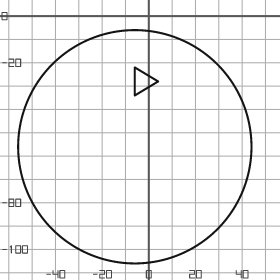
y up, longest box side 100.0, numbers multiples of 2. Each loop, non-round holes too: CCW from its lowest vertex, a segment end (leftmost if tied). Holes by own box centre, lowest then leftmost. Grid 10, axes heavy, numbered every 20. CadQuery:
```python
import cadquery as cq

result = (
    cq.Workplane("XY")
    .moveTo(-6.0, -56.0)
    .circle(50.0)
    .moveTo(-6.0, -34.0)
    .lineTo(4.0, -28.0)
    .lineTo(-6.0, -22.0)
    .close()
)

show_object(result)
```